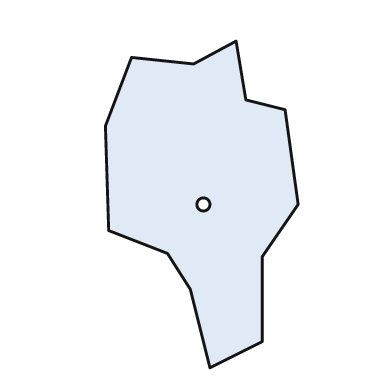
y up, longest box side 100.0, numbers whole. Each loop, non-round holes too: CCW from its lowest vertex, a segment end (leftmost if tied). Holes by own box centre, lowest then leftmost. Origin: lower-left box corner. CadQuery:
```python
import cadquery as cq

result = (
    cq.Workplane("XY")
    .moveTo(32.0, 0.0)
    .lineTo(48.0, 8.0)
    .lineTo(48.0, 34.0)
    .lineTo(59.0, 50.0)
    .lineTo(55.0, 79.0)
    .lineTo(43.0, 82.0)
    .lineTo(40.0, 100.0)
    .lineTo(27.0, 93.0)
    .lineTo(8.0, 95.0)
    .lineTo(0.0, 74.0)
    .lineTo(1.0, 42.0)
    .lineTo(19.0, 35.0)
    .lineTo(26.0, 24.0)
    .close()
    .moveTo(30.0, 50.0)
    .circle(2.0)
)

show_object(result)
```